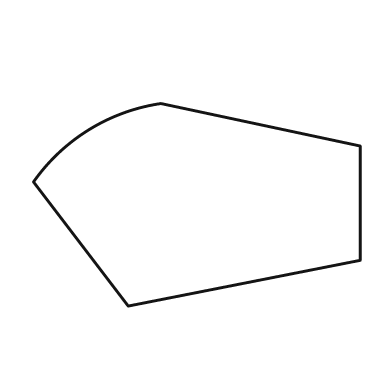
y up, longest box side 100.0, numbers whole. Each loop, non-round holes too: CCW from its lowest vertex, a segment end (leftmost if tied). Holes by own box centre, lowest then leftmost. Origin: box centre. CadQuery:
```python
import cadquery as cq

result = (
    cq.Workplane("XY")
    .moveTo(-21.0, -31.0)
    .lineTo(50.0, -17.0)
    .lineTo(50.0, 18.0)
    .lineTo(-11.0, 31.0)
    .threePointArc((-33.0, 23.0), (-50.0, 7.0))
    .close()
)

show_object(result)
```